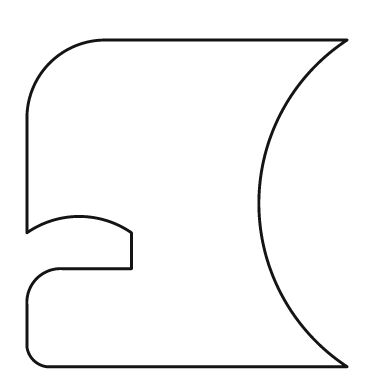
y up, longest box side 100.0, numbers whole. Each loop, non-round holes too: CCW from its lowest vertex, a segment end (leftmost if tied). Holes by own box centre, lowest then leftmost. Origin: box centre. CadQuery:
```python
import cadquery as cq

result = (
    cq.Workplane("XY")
    .moveTo(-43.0, -50.0)
    .lineTo(49.0, -50.0)
    .threePointArc((22.0, 0.0), (49.0, 50.0))
    .lineTo(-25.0, 50.0)
    .threePointArc((-42.0, 43.0), (-49.0, 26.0))
    .lineTo(-49.0, -9.0)
    .threePointArc((-33.0, -4.0), (-17.0, -9.0))
    .lineTo(-17.0, -20.0)
    .lineTo(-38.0, -20.0)
    .threePointArc((-46.0, -23.0), (-49.0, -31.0))
    .lineTo(-49.0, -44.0)
    .threePointArc((-47.0, -48.0), (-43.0, -50.0))
    .close()
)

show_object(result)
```